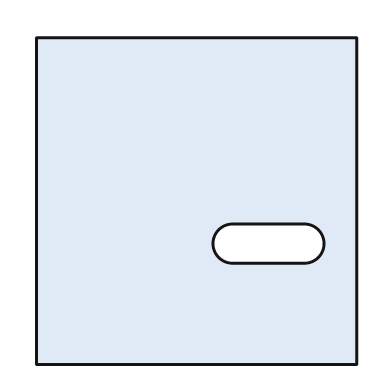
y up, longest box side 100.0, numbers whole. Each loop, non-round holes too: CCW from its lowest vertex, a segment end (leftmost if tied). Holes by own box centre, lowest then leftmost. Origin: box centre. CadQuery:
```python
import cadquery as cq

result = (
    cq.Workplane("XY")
    .moveTo(-49.0, -50.0)
    .lineTo(49.0, -50.0)
    .lineTo(49.0, 50.0)
    .lineTo(-49.0, 50.0)
    .close()
    .moveTo(11.0, -19.0)
    .lineTo(33.0, -19.0)
    .threePointArc((39.0, -13.0), (33.0, -7.0))
    .lineTo(11.0, -7.0)
    .threePointArc((5.0, -13.0), (11.0, -19.0))
    .close()
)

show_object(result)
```